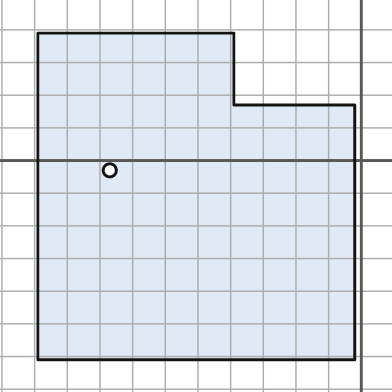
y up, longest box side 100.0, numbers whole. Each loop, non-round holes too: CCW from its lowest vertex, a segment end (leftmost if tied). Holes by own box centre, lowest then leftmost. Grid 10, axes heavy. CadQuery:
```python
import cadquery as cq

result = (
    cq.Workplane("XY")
    .moveTo(-99.0, -61.0)
    .lineTo(-2.0, -61.0)
    .lineTo(-2.0, 17.0)
    .lineTo(-39.0, 17.0)
    .lineTo(-39.0, 39.0)
    .lineTo(-99.0, 39.0)
    .close()
    .moveTo(-77.0, -3.0)
    .circle(2.0)
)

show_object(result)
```